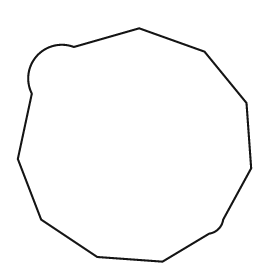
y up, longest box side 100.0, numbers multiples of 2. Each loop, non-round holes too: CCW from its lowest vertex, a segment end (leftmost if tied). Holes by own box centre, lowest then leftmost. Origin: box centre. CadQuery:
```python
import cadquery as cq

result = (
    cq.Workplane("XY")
    .moveTo(12.0, -50.0)
    .lineTo(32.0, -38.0)
    .threePointArc((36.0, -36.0), (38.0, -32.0))
    .lineTo(50.0, -10.0)
    .lineTo(48.0, 18.0)
    .lineTo(30.0, 40.0)
    .lineTo(2.0, 50.0)
    .lineTo(-26.0, 42.0)
    .threePointArc((-42.0, 38.0), (-44.0, 22.0))
    .lineTo(-50.0, -6.0)
    .lineTo(-40.0, -32.0)
    .lineTo(-16.0, -48.0)
    .close()
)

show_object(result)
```